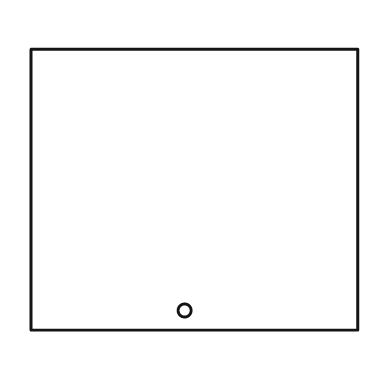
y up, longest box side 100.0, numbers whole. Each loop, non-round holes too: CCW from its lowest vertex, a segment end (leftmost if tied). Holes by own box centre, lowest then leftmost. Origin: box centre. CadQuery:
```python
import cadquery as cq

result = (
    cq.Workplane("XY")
    .moveTo(-50.0, -43.0)
    .lineTo(50.0, -43.0)
    .lineTo(50.0, 43.0)
    .lineTo(-50.0, 43.0)
    .close()
    .moveTo(-3.0, -37.0)
    .circle(2.0)
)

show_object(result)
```